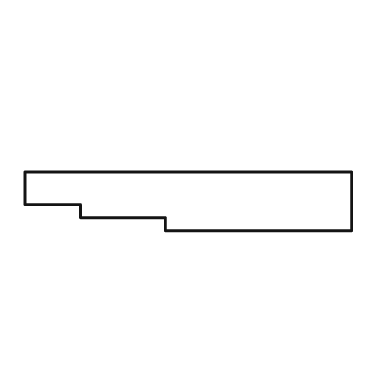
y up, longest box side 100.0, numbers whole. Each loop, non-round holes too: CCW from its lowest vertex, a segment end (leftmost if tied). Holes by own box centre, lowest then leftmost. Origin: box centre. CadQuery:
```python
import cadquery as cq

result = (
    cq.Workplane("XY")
    .moveTo(-7.0, -9.0)
    .lineTo(50.0, -9.0)
    .lineTo(50.0, 9.0)
    .lineTo(-50.0, 9.0)
    .lineTo(-50.0, -1.0)
    .lineTo(-33.0, -1.0)
    .lineTo(-33.0, -5.0)
    .lineTo(-7.0, -5.0)
    .close()
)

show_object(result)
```